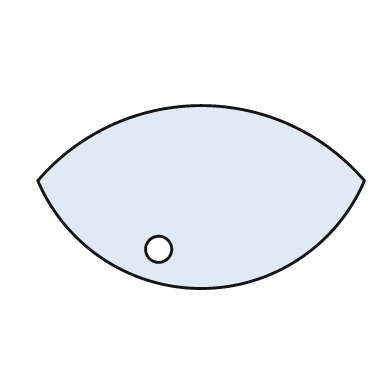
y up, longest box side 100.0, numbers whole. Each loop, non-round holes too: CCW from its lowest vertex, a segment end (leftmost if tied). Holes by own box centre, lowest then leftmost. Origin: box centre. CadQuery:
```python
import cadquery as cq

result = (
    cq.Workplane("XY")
    .moveTo(-50.0, 5.0)
    .threePointArc((0.0, -28.0), (50.0, 5.0))
    .threePointArc((0.0, 28.0), (-50.0, 5.0))
    .close()
    .moveTo(-13.0, -16.0)
    .circle(4.0)
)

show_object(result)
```